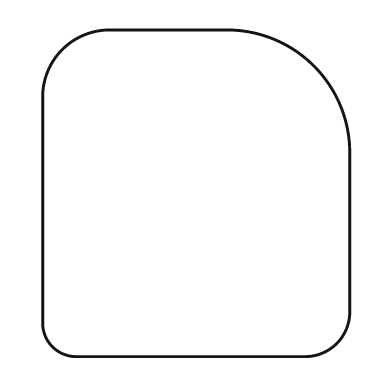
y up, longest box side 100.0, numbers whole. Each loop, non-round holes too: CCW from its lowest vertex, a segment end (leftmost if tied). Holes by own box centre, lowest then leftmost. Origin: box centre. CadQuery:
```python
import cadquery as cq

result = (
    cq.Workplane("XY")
    .moveTo(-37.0, -50.0)
    .lineTo(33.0, -50.0)
    .threePointArc((43.0, -46.0), (47.0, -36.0))
    .lineTo(47.0, 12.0)
    .threePointArc((36.0, 39.0), (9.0, 50.0))
    .lineTo(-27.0, 50.0)
    .threePointArc((-41.0, 44.0), (-47.0, 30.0))
    .lineTo(-47.0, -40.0)
    .threePointArc((-44.0, -47.0), (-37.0, -50.0))
    .close()
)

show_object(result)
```